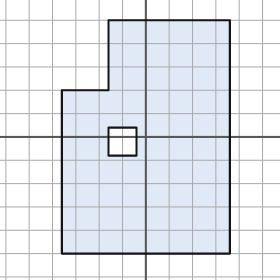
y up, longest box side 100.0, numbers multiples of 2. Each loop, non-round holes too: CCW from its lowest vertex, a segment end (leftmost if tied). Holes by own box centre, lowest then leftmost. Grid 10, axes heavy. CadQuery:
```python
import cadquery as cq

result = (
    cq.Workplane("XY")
    .moveTo(-36.0, -50.0)
    .lineTo(36.0, -50.0)
    .lineTo(36.0, 50.0)
    .lineTo(-16.0, 50.0)
    .lineTo(-16.0, 20.0)
    .lineTo(-36.0, 20.0)
    .close()
    .moveTo(-16.0, -8.0)
    .lineTo(-4.0, -8.0)
    .lineTo(-4.0, 4.0)
    .lineTo(-16.0, 4.0)
    .close()
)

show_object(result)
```